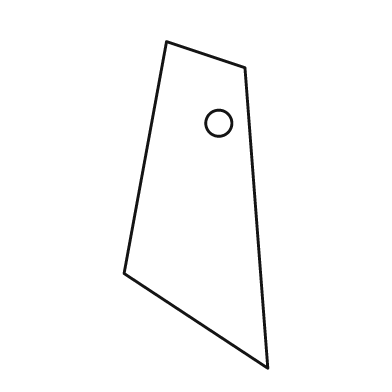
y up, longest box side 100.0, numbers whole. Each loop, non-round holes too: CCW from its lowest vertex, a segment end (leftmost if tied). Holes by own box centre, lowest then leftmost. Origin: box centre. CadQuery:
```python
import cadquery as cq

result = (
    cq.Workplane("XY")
    .moveTo(22.0, -50.0)
    .lineTo(15.0, 42.0)
    .lineTo(-9.0, 50.0)
    .lineTo(-22.0, -21.0)
    .close()
    .moveTo(7.0, 25.0)
    .circle(4.0)
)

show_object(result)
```